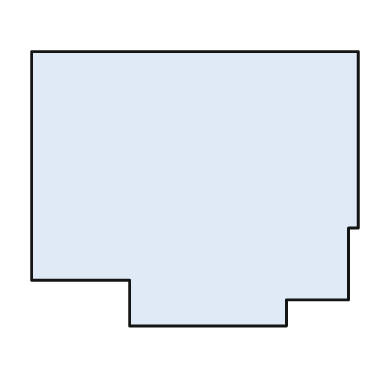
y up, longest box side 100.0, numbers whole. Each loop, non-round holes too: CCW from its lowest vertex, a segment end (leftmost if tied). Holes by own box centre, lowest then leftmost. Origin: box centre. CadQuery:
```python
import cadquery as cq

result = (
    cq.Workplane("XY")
    .moveTo(-20.0, -42.0)
    .lineTo(28.0, -42.0)
    .lineTo(28.0, -34.0)
    .lineTo(47.0, -34.0)
    .lineTo(47.0, -12.0)
    .lineTo(50.0, -12.0)
    .lineTo(50.0, 42.0)
    .lineTo(-50.0, 42.0)
    .lineTo(-50.0, -28.0)
    .lineTo(-20.0, -28.0)
    .close()
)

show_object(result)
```